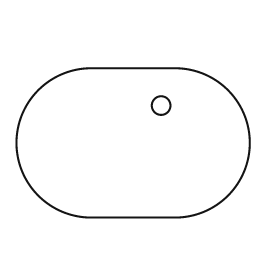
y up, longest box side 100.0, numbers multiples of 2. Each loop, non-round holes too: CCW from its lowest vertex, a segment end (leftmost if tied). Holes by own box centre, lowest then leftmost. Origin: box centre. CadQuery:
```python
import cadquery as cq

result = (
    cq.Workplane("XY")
    .moveTo(-18.0, -32.0)
    .lineTo(18.0, -32.0)
    .threePointArc((50.0, 0.0), (18.0, 32.0))
    .lineTo(-18.0, 32.0)
    .threePointArc((-50.0, 0.0), (-18.0, -32.0))
    .close()
    .moveTo(12.0, 16.0)
    .circle(4.0)
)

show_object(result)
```